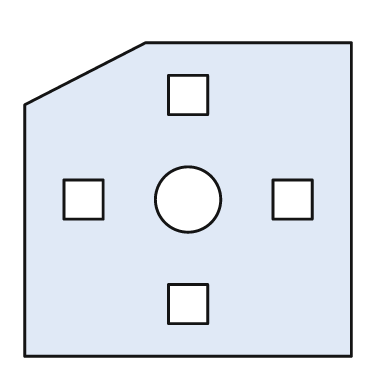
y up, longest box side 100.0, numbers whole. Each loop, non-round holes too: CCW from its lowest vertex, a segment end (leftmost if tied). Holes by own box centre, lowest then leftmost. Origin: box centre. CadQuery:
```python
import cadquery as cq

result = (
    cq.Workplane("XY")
    .moveTo(-50.0, -48.0)
    .lineTo(50.0, -48.0)
    .lineTo(50.0, 48.0)
    .lineTo(-13.0, 48.0)
    .lineTo(-50.0, 29.0)
    .close()
    .moveTo(-6.0, -38.0)
    .lineTo(6.0, -38.0)
    .lineTo(6.0, -26.0)
    .lineTo(-6.0, -26.0)
    .close()
    .moveTo(-38.0, -6.0)
    .lineTo(-26.0, -6.0)
    .lineTo(-26.0, 6.0)
    .lineTo(-38.0, 6.0)
    .close()
    .moveTo(0.0, 0.0)
    .circle(10.0)
    .moveTo(26.0, -6.0)
    .lineTo(38.0, -6.0)
    .lineTo(38.0, 6.0)
    .lineTo(26.0, 6.0)
    .close()
    .moveTo(-6.0, 26.0)
    .lineTo(6.0, 26.0)
    .lineTo(6.0, 38.0)
    .lineTo(-6.0, 38.0)
    .close()
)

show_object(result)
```